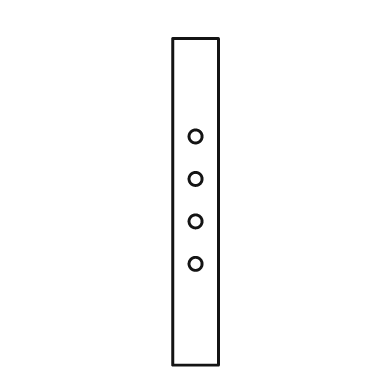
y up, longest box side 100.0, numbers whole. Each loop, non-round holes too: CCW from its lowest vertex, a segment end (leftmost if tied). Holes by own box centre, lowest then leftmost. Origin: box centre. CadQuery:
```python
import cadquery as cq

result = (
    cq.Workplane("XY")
    .moveTo(-7.0, -50.0)
    .lineTo(7.0, -50.0)
    .lineTo(7.0, 50.0)
    .lineTo(-7.0, 50.0)
    .close()
    .moveTo(0.0, -19.0)
    .circle(2.0)
    .moveTo(0.0, -6.0)
    .circle(2.0)
    .moveTo(0.0, 7.0)
    .circle(2.0)
    .moveTo(0.0, 20.0)
    .circle(2.0)
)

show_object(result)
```